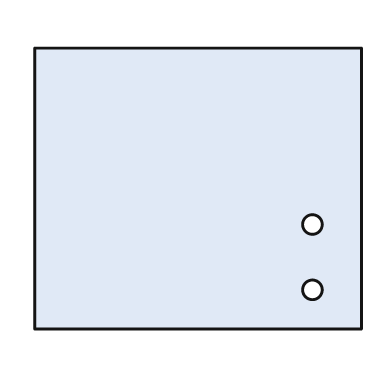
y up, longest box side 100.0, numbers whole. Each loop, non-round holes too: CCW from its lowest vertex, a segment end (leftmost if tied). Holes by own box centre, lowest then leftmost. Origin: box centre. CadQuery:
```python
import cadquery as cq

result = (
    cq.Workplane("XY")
    .moveTo(-50.0, -43.0)
    .lineTo(50.0, -43.0)
    .lineTo(50.0, 43.0)
    .lineTo(-50.0, 43.0)
    .close()
    .moveTo(35.0, -31.0)
    .circle(3.0)
    .moveTo(35.0, -11.0)
    .circle(3.0)
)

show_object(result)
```